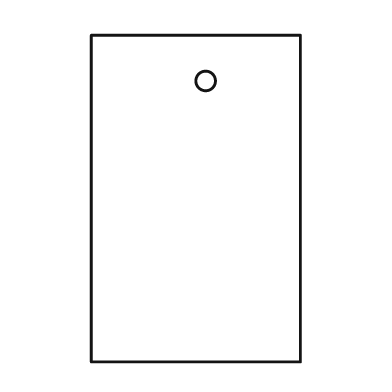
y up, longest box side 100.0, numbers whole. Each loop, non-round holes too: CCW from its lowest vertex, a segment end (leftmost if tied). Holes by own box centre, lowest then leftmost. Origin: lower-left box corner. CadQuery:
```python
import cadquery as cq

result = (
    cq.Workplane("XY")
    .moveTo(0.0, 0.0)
    .lineTo(64.0, 0.0)
    .lineTo(64.0, 100.0)
    .lineTo(0.0, 100.0)
    .close()
    .moveTo(35.0, 86.0)
    .circle(3.0)
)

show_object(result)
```